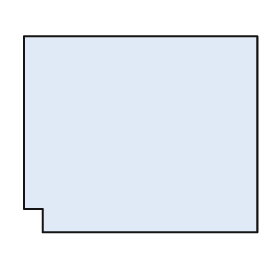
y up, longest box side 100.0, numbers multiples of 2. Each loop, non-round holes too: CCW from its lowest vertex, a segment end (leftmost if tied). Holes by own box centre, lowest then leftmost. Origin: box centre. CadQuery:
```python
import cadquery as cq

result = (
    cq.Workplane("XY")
    .moveTo(-42.0, -42.0)
    .lineTo(50.0, -42.0)
    .lineTo(50.0, 42.0)
    .lineTo(-50.0, 42.0)
    .lineTo(-50.0, -32.0)
    .lineTo(-42.0, -32.0)
    .close()
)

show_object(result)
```